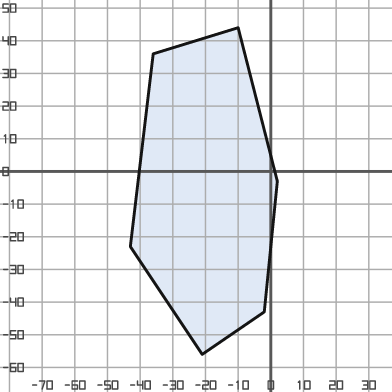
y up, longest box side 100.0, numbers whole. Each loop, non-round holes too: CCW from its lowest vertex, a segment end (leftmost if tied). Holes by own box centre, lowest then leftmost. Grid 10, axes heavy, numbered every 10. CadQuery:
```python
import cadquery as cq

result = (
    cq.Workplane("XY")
    .moveTo(-21.0, -56.0)
    .lineTo(-2.0, -43.0)
    .lineTo(2.0, -3.0)
    .lineTo(-10.0, 44.0)
    .lineTo(-36.0, 36.0)
    .lineTo(-43.0, -23.0)
    .close()
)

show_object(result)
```